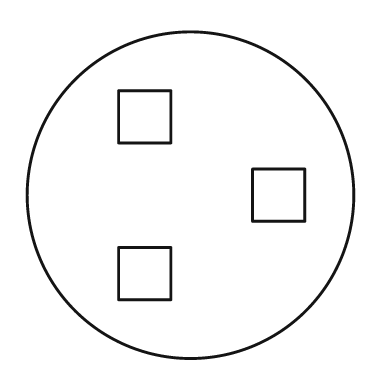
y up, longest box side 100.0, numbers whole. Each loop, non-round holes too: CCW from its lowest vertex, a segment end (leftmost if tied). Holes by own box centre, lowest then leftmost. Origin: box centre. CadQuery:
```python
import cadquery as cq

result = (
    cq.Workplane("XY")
    .moveTo(0.0, 0.0)
    .circle(50.0)
    .moveTo(-22.0, -32.0)
    .lineTo(-6.0, -32.0)
    .lineTo(-6.0, -16.0)
    .lineTo(-22.0, -16.0)
    .close()
    .moveTo(19.0, -8.0)
    .lineTo(35.0, -8.0)
    .lineTo(35.0, 8.0)
    .lineTo(19.0, 8.0)
    .close()
    .moveTo(-22.0, 16.0)
    .lineTo(-6.0, 16.0)
    .lineTo(-6.0, 32.0)
    .lineTo(-22.0, 32.0)
    .close()
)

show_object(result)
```